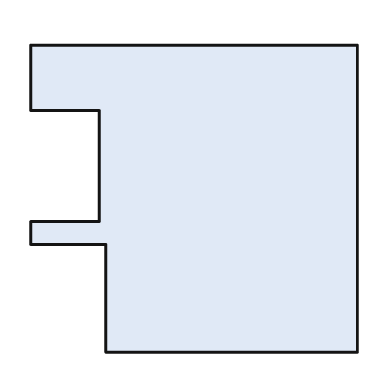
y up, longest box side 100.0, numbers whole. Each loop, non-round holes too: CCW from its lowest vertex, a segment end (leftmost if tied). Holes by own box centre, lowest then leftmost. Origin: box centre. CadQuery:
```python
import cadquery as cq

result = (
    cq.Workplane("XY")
    .moveTo(-27.0, -47.0)
    .lineTo(50.0, -47.0)
    .lineTo(50.0, 47.0)
    .lineTo(-50.0, 47.0)
    .lineTo(-50.0, 27.0)
    .lineTo(-29.0, 27.0)
    .lineTo(-29.0, -7.0)
    .lineTo(-50.0, -7.0)
    .lineTo(-50.0, -14.0)
    .lineTo(-27.0, -14.0)
    .close()
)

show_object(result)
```